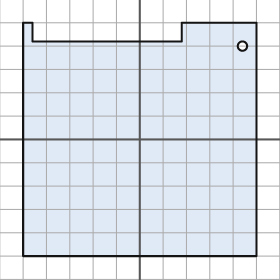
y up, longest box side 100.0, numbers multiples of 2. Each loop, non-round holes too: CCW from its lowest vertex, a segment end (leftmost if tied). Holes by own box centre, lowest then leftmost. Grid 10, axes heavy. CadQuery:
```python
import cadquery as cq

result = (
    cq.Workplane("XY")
    .moveTo(-50.0, -50.0)
    .lineTo(50.0, -50.0)
    .lineTo(50.0, 50.0)
    .lineTo(18.0, 50.0)
    .lineTo(18.0, 42.0)
    .lineTo(-46.0, 42.0)
    .lineTo(-46.0, 50.0)
    .lineTo(-50.0, 50.0)
    .close()
    .moveTo(44.0, 40.0)
    .circle(2.0)
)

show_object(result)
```